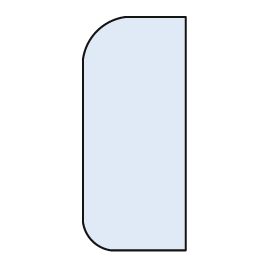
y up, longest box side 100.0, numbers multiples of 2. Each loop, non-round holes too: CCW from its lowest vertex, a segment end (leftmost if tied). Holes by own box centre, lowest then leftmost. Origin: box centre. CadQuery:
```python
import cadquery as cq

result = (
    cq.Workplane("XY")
    .moveTo(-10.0, -50.0)
    .lineTo(22.0, -50.0)
    .lineTo(22.0, 50.0)
    .lineTo(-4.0, 50.0)
    .threePointArc((-16.0, 44.0), (-22.0, 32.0))
    .lineTo(-22.0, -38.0)
    .threePointArc((-18.0, -46.0), (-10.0, -50.0))
    .close()
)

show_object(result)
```